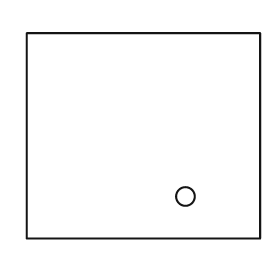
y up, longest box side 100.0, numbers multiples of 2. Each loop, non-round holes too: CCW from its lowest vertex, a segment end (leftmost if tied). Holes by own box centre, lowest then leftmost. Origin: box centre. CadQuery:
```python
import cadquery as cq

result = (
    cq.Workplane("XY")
    .moveTo(-50.0, -44.0)
    .lineTo(50.0, -44.0)
    .lineTo(50.0, 44.0)
    .lineTo(-50.0, 44.0)
    .close()
    .moveTo(18.0, -26.0)
    .circle(4.0)
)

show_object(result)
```